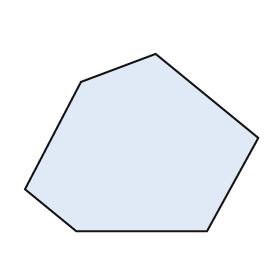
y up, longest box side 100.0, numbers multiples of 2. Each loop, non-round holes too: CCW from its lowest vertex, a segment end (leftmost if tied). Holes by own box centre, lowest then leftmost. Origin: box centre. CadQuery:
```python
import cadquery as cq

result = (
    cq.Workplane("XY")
    .moveTo(-28.0, -38.0)
    .lineTo(28.0, -38.0)
    .lineTo(50.0, 2.0)
    .lineTo(6.0, 38.0)
    .lineTo(-26.0, 26.0)
    .lineTo(-50.0, -20.0)
    .close()
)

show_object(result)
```